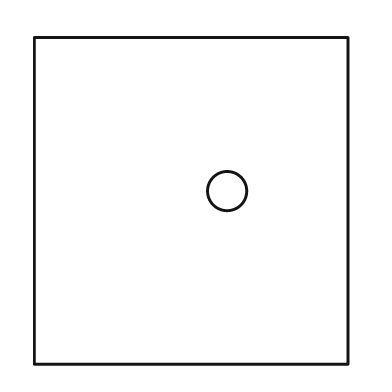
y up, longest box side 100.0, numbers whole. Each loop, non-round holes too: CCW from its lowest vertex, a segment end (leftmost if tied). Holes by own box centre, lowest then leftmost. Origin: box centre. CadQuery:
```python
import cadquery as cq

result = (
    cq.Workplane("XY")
    .moveTo(-48.0, -50.0)
    .lineTo(48.0, -50.0)
    .lineTo(48.0, 50.0)
    .lineTo(-48.0, 50.0)
    .close()
    .moveTo(11.0, 3.0)
    .circle(6.0)
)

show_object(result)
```